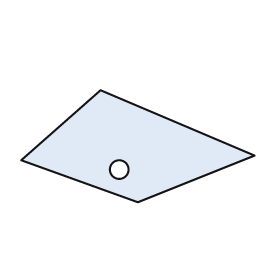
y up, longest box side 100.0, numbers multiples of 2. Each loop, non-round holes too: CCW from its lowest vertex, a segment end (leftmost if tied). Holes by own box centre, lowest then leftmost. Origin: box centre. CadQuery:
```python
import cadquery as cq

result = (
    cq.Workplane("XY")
    .moveTo(0.0, -24.0)
    .lineTo(50.0, -4.0)
    .lineTo(-16.0, 24.0)
    .lineTo(-50.0, -6.0)
    .close()
    .moveTo(-8.0, -10.0)
    .circle(4.0)
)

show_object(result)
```